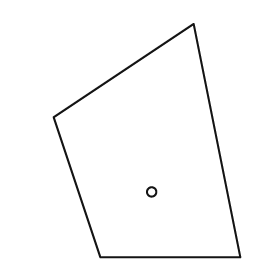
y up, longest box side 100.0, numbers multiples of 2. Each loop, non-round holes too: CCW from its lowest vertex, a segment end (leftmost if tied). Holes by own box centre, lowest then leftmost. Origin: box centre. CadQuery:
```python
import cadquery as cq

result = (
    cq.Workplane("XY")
    .moveTo(-20.0, -50.0)
    .lineTo(40.0, -50.0)
    .lineTo(20.0, 50.0)
    .lineTo(-40.0, 10.0)
    .close()
    .moveTo(2.0, -22.0)
    .circle(2.0)
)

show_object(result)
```